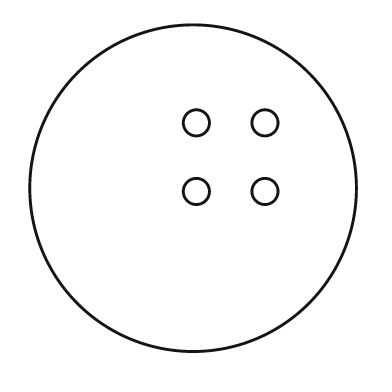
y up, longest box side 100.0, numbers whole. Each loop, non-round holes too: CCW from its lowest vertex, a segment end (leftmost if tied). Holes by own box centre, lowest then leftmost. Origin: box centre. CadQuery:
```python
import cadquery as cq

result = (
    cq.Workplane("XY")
    .moveTo(0.0, 0.0)
    .circle(50.0)
    .moveTo(1.0, -1.0)
    .circle(4.0)
    .moveTo(22.0, -1.0)
    .circle(4.0)
    .moveTo(1.0, 20.0)
    .circle(4.0)
    .moveTo(22.0, 20.0)
    .circle(4.0)
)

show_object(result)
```